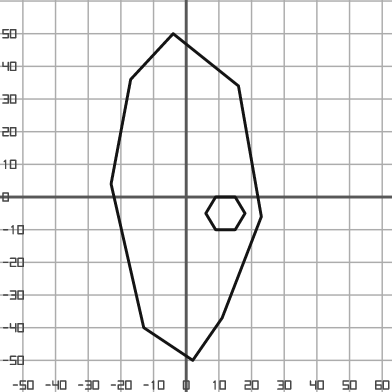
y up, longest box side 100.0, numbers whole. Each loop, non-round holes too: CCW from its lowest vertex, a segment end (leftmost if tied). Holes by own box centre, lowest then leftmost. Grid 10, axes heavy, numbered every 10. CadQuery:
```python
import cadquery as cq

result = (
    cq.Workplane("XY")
    .moveTo(2.0, -50.0)
    .lineTo(11.0, -37.0)
    .lineTo(23.0, -6.0)
    .lineTo(16.0, 34.0)
    .lineTo(-4.0, 50.0)
    .lineTo(-17.0, 36.0)
    .lineTo(-23.0, 4.0)
    .lineTo(-13.0, -40.0)
    .close()
    .moveTo(9.0, -10.0)
    .lineTo(15.0, -10.0)
    .lineTo(18.0, -5.0)
    .lineTo(15.0, 0.0)
    .lineTo(9.0, 0.0)
    .lineTo(6.0, -5.0)
    .close()
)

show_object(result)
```